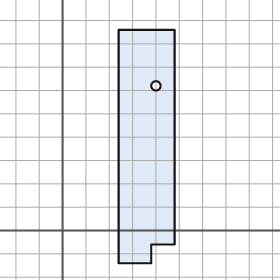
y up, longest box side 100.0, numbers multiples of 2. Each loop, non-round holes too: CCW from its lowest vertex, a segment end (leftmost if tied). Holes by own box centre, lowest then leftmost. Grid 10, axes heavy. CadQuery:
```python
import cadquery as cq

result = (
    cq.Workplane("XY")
    .moveTo(24.0, -14.0)
    .lineTo(38.0, -14.0)
    .lineTo(38.0, -6.0)
    .lineTo(48.0, -6.0)
    .lineTo(48.0, 86.0)
    .lineTo(24.0, 86.0)
    .close()
    .moveTo(40.0, 62.0)
    .circle(2.0)
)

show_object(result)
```